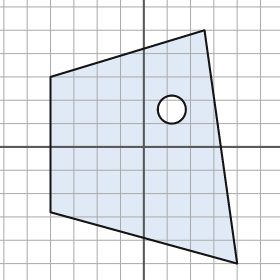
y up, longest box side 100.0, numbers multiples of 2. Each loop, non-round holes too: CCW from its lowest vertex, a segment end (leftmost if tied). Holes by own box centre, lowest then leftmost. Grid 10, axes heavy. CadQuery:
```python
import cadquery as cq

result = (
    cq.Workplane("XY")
    .moveTo(40.0, -50.0)
    .lineTo(26.0, 50.0)
    .lineTo(-40.0, 30.0)
    .lineTo(-40.0, -28.0)
    .close()
    .moveTo(12.0, 16.0)
    .circle(6.0)
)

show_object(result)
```